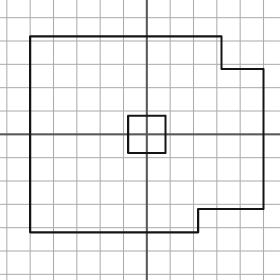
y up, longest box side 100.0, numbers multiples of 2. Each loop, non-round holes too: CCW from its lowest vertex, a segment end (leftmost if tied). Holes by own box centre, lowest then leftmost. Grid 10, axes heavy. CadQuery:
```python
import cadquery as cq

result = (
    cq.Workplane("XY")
    .moveTo(-50.0, -42.0)
    .lineTo(22.0, -42.0)
    .lineTo(22.0, -32.0)
    .lineTo(50.0, -32.0)
    .lineTo(50.0, 28.0)
    .lineTo(32.0, 28.0)
    .lineTo(32.0, 42.0)
    .lineTo(-50.0, 42.0)
    .close()
    .moveTo(-8.0, -8.0)
    .lineTo(8.0, -8.0)
    .lineTo(8.0, 8.0)
    .lineTo(-8.0, 8.0)
    .close()
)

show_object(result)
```